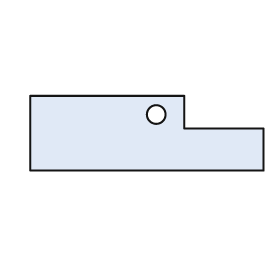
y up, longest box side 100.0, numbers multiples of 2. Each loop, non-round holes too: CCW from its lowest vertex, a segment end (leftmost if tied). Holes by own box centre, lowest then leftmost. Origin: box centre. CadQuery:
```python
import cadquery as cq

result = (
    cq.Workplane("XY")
    .moveTo(-50.0, -16.0)
    .lineTo(50.0, -16.0)
    .lineTo(50.0, 2.0)
    .lineTo(16.0, 2.0)
    .lineTo(16.0, 16.0)
    .lineTo(-50.0, 16.0)
    .close()
    .moveTo(4.0, 8.0)
    .circle(4.0)
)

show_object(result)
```